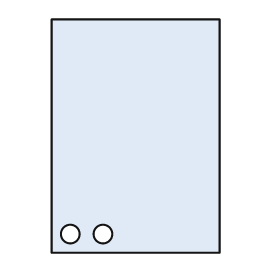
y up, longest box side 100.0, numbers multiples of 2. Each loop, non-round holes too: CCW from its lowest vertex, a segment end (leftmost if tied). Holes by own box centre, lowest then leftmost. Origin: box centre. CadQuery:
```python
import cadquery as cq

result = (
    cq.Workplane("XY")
    .moveTo(-36.0, -50.0)
    .lineTo(36.0, -50.0)
    .lineTo(36.0, 50.0)
    .lineTo(-36.0, 50.0)
    .close()
    .moveTo(-28.0, -42.0)
    .circle(4.0)
    .moveTo(-14.0, -42.0)
    .circle(4.0)
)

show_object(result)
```